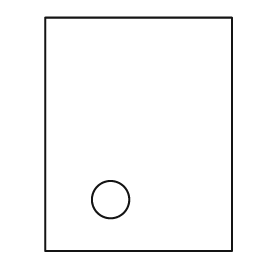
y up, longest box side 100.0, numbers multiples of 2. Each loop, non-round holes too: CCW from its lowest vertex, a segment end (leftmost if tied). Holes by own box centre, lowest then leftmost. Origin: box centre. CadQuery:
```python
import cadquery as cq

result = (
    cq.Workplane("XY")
    .moveTo(-40.0, -50.0)
    .lineTo(40.0, -50.0)
    .lineTo(40.0, 50.0)
    .lineTo(-40.0, 50.0)
    .close()
    .moveTo(-12.0, -28.0)
    .circle(8.0)
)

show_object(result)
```